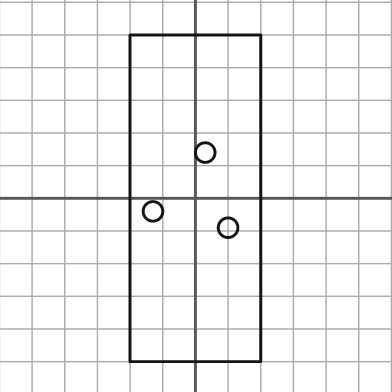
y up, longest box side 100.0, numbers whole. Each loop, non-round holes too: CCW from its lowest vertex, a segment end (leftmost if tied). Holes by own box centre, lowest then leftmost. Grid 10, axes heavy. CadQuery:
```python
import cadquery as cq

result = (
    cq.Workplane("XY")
    .moveTo(-20.0, -50.0)
    .lineTo(20.0, -50.0)
    .lineTo(20.0, 50.0)
    .lineTo(-20.0, 50.0)
    .close()
    .moveTo(10.0, -9.0)
    .circle(3.0)
    .moveTo(-13.0, -4.0)
    .circle(3.0)
    .moveTo(3.0, 14.0)
    .circle(3.0)
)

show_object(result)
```